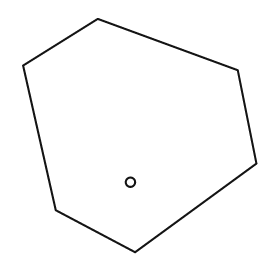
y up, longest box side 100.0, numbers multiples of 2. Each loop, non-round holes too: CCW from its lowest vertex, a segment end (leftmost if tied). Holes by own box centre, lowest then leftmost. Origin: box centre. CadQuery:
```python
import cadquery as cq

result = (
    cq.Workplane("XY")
    .moveTo(-2.0, -50.0)
    .lineTo(50.0, -12.0)
    .lineTo(42.0, 28.0)
    .lineTo(-18.0, 50.0)
    .lineTo(-50.0, 30.0)
    .lineTo(-36.0, -32.0)
    .close()
    .moveTo(-4.0, -20.0)
    .circle(2.0)
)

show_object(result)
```